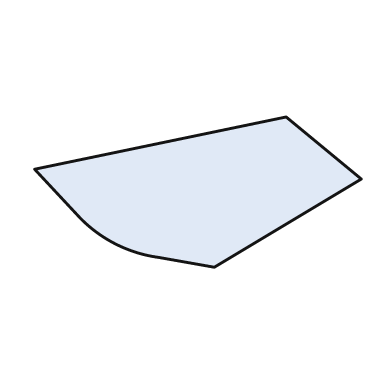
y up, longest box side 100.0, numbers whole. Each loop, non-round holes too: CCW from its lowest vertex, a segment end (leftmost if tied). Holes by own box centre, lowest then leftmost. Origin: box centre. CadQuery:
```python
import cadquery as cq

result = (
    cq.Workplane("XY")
    .moveTo(5.0, -23.0)
    .lineTo(50.0, 4.0)
    .lineTo(27.0, 23.0)
    .lineTo(-50.0, 7.0)
    .lineTo(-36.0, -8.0)
    .threePointArc((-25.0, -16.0), (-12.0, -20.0))
    .close()
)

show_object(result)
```